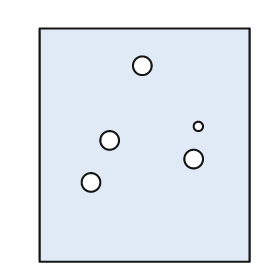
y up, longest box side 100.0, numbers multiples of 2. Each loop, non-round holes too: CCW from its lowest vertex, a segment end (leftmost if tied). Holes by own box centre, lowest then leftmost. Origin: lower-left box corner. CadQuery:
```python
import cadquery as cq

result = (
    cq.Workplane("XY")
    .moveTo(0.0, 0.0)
    .lineTo(90.0, 0.0)
    .lineTo(90.0, 100.0)
    .lineTo(0.0, 100.0)
    .close()
    .moveTo(22.0, 34.0)
    .circle(4.0)
    .moveTo(66.0, 44.0)
    .circle(4.0)
    .moveTo(30.0, 52.0)
    .circle(4.0)
    .moveTo(68.0, 58.0)
    .circle(2.0)
    .moveTo(44.0, 84.0)
    .circle(4.0)
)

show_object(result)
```